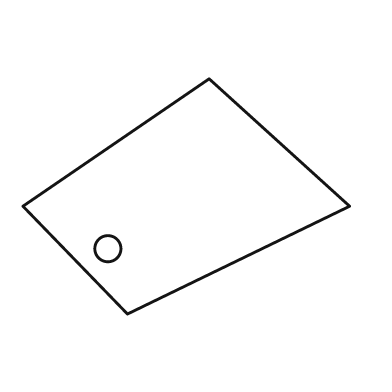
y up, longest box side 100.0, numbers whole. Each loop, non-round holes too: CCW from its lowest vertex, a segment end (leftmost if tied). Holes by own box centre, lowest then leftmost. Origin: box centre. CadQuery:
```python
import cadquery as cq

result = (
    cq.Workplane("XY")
    .moveTo(-18.0, -36.0)
    .lineTo(50.0, -3.0)
    .lineTo(7.0, 36.0)
    .lineTo(-50.0, -3.0)
    .close()
    .moveTo(-24.0, -16.0)
    .circle(4.0)
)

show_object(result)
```